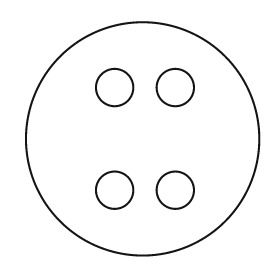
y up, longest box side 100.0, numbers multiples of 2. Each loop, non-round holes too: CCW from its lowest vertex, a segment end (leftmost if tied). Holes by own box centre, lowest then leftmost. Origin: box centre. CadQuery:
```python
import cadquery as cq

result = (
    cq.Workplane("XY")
    .moveTo(0.0, 0.0)
    .circle(50.0)
    .moveTo(-12.0, -22.0)
    .circle(8.0)
    .moveTo(14.0, -22.0)
    .circle(8.0)
    .moveTo(-12.0, 22.0)
    .circle(8.0)
    .moveTo(14.0, 22.0)
    .circle(8.0)
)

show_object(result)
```